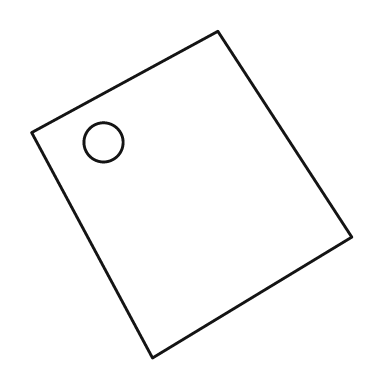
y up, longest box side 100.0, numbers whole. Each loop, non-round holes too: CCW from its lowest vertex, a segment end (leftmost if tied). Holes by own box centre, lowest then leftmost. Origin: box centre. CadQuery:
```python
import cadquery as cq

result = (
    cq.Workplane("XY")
    .moveTo(-12.0, -50.0)
    .lineTo(49.0, -13.0)
    .lineTo(8.0, 50.0)
    .lineTo(-49.0, 19.0)
    .close()
    .moveTo(-27.0, 16.0)
    .circle(6.0)
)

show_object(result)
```